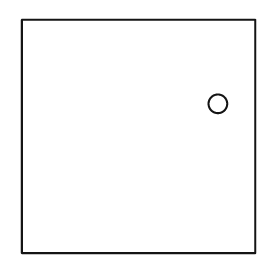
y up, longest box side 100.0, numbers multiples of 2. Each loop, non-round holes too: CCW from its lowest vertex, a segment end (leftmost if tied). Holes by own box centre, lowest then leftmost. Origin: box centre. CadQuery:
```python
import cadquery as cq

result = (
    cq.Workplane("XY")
    .moveTo(-50.0, -50.0)
    .lineTo(50.0, -50.0)
    .lineTo(50.0, 50.0)
    .lineTo(-50.0, 50.0)
    .close()
    .moveTo(34.0, 14.0)
    .circle(4.0)
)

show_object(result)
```